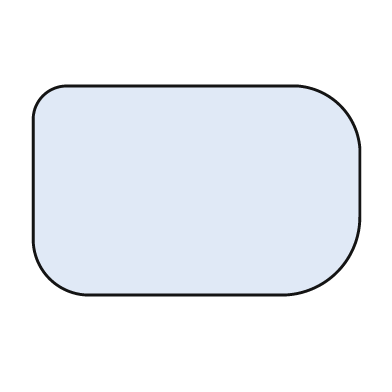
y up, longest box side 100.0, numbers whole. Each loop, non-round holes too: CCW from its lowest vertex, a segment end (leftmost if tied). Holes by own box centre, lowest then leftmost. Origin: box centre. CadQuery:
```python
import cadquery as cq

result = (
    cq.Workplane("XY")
    .moveTo(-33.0, -32.0)
    .lineTo(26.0, -32.0)
    .threePointArc((43.0, -25.0), (50.0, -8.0))
    .lineTo(50.0, 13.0)
    .threePointArc((44.0, 26.0), (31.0, 32.0))
    .lineTo(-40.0, 32.0)
    .threePointArc((-47.0, 29.0), (-50.0, 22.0))
    .lineTo(-50.0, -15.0)
    .threePointArc((-45.0, -27.0), (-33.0, -32.0))
    .close()
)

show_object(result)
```